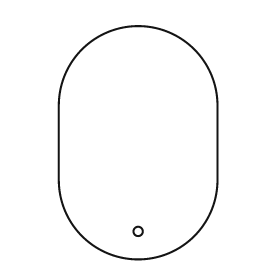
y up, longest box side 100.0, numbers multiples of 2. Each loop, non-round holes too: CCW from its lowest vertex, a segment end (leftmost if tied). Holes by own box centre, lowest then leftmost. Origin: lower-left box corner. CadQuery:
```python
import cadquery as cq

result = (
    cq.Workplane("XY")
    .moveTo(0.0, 34.0)
    .threePointArc((34.0, 0.0), (68.0, 34.0))
    .lineTo(68.0, 66.0)
    .threePointArc((34.0, 100.0), (0.0, 66.0))
    .close()
    .moveTo(34.0, 12.0)
    .circle(2.0)
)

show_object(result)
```